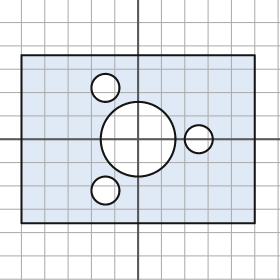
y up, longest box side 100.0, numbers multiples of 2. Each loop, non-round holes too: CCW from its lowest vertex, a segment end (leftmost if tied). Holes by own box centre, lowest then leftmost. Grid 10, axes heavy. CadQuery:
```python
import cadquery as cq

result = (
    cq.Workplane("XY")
    .moveTo(-50.0, -36.0)
    .lineTo(50.0, -36.0)
    .lineTo(50.0, 36.0)
    .lineTo(-50.0, 36.0)
    .close()
    .moveTo(-14.0, -22.0)
    .circle(6.0)
    .moveTo(0.0, 0.0)
    .circle(16.0)
    .moveTo(26.0, 0.0)
    .circle(6.0)
    .moveTo(-14.0, 22.0)
    .circle(6.0)
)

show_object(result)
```